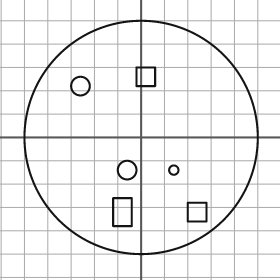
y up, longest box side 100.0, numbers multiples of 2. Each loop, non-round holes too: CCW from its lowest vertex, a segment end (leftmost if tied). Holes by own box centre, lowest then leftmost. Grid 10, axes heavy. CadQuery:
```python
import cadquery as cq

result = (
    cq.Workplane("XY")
    .moveTo(0.0, 0.0)
    .circle(50.0)
    .moveTo(-12.0, -38.0)
    .lineTo(-4.0, -38.0)
    .lineTo(-4.0, -26.0)
    .lineTo(-12.0, -26.0)
    .close()
    .moveTo(20.0, -36.0)
    .lineTo(28.0, -36.0)
    .lineTo(28.0, -28.0)
    .lineTo(20.0, -28.0)
    .close()
    .moveTo(-6.0, -14.0)
    .circle(4.0)
    .moveTo(14.0, -14.0)
    .circle(2.0)
    .moveTo(-26.0, 22.0)
    .circle(4.0)
    .moveTo(-2.0, 22.0)
    .lineTo(6.0, 22.0)
    .lineTo(6.0, 30.0)
    .lineTo(-2.0, 30.0)
    .close()
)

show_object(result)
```